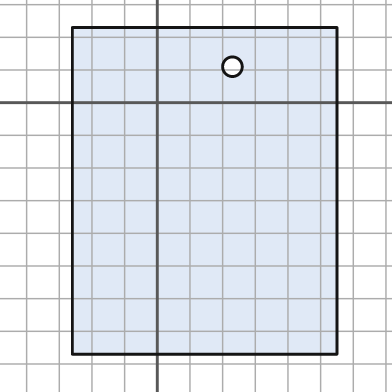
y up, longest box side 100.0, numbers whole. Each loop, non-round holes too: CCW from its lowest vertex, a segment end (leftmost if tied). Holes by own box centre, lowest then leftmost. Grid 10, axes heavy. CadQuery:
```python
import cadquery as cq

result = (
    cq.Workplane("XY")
    .moveTo(-26.0, -77.0)
    .lineTo(55.0, -77.0)
    .lineTo(55.0, 23.0)
    .lineTo(-26.0, 23.0)
    .close()
    .moveTo(23.0, 11.0)
    .circle(3.0)
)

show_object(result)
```